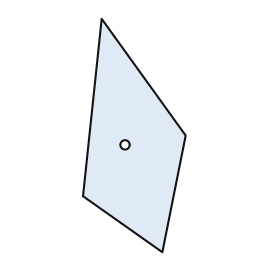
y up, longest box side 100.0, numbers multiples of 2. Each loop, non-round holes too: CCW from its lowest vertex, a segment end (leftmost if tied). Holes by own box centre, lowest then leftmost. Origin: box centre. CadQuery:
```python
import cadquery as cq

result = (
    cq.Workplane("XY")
    .moveTo(12.0, -50.0)
    .lineTo(22.0, 0.0)
    .lineTo(-14.0, 50.0)
    .lineTo(-22.0, -26.0)
    .close()
    .moveTo(-4.0, -4.0)
    .circle(2.0)
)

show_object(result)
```